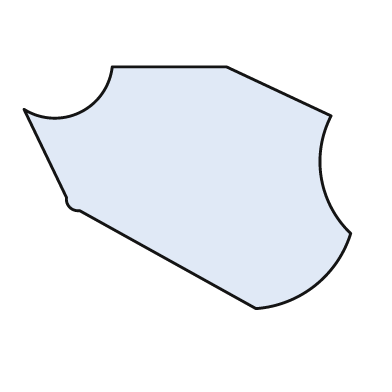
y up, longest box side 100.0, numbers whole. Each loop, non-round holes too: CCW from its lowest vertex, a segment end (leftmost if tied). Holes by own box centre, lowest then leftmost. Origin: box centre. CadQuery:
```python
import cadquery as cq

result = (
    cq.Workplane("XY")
    .moveTo(21.0, -37.0)
    .threePointArc((39.0, -30.0), (50.0, -14.0))
    .threePointArc((41.0, 3.0), (44.0, 22.0))
    .lineTo(12.0, 37.0)
    .lineTo(-23.0, 37.0)
    .threePointArc((-33.0, 23.0), (-50.0, 24.0))
    .lineTo(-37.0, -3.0)
    .threePointArc((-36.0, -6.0), (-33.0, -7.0))
    .close()
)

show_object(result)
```